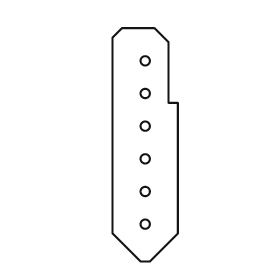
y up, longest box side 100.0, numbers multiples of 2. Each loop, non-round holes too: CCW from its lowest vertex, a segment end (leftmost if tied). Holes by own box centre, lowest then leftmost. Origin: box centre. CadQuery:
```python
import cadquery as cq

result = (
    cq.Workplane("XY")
    .moveTo(-2.0, -50.0)
    .lineTo(2.0, -50.0)
    .lineTo(14.0, -38.0)
    .lineTo(14.0, 18.0)
    .lineTo(10.0, 18.0)
    .lineTo(10.0, 44.0)
    .lineTo(4.0, 50.0)
    .lineTo(-10.0, 50.0)
    .lineTo(-14.0, 46.0)
    .lineTo(-14.0, -38.0)
    .close()
    .moveTo(0.0, -34.0)
    .circle(2.0)
    .moveTo(0.0, -20.0)
    .circle(2.0)
    .moveTo(0.0, -6.0)
    .circle(2.0)
    .moveTo(0.0, 8.0)
    .circle(2.0)
    .moveTo(0.0, 22.0)
    .circle(2.0)
    .moveTo(0.0, 36.0)
    .circle(2.0)
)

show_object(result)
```